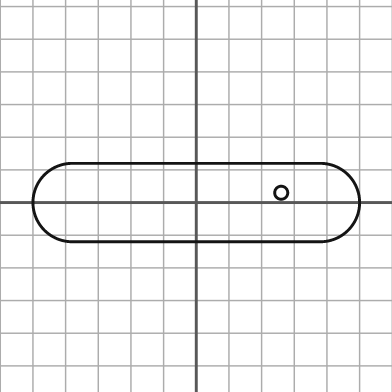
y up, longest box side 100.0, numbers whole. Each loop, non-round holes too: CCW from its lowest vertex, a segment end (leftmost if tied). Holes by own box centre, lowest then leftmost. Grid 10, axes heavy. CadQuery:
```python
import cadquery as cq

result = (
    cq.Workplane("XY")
    .moveTo(-38.0, -12.0)
    .lineTo(38.0, -12.0)
    .threePointArc((50.0, 0.0), (38.0, 12.0))
    .lineTo(-38.0, 12.0)
    .threePointArc((-50.0, 0.0), (-38.0, -12.0))
    .close()
    .moveTo(26.0, 3.0)
    .circle(2.0)
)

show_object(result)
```